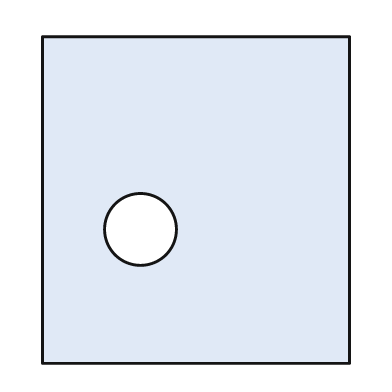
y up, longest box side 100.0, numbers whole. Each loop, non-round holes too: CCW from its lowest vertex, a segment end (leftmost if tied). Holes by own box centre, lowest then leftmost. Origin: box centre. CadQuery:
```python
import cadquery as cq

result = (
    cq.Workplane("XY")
    .moveTo(-47.0, -50.0)
    .lineTo(47.0, -50.0)
    .lineTo(47.0, 50.0)
    .lineTo(-47.0, 50.0)
    .close()
    .moveTo(-17.0, -9.0)
    .circle(11.0)
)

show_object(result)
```